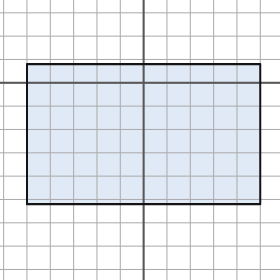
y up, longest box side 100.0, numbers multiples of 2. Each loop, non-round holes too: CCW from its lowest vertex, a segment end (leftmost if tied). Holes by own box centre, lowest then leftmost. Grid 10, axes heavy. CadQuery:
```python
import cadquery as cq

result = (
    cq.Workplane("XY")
    .moveTo(-50.0, -52.0)
    .lineTo(50.0, -52.0)
    .lineTo(50.0, 8.0)
    .lineTo(-50.0, 8.0)
    .close()
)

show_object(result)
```